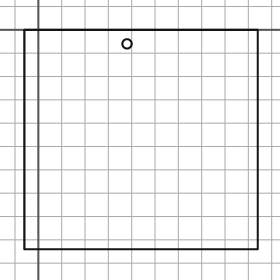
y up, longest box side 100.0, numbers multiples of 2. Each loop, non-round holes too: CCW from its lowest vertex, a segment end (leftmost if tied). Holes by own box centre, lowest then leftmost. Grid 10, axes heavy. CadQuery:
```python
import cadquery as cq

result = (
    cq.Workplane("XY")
    .moveTo(-6.0, -94.0)
    .lineTo(94.0, -94.0)
    .lineTo(94.0, 0.0)
    .lineTo(-6.0, 0.0)
    .close()
    .moveTo(38.0, -6.0)
    .circle(2.0)
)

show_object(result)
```